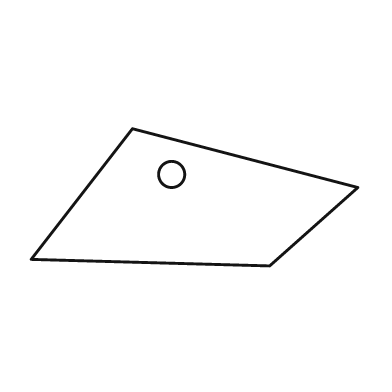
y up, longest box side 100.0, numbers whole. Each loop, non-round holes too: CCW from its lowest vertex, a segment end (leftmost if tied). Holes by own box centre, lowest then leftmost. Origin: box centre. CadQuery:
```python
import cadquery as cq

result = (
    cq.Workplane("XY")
    .moveTo(23.0, -21.0)
    .lineTo(50.0, 3.0)
    .lineTo(-19.0, 21.0)
    .lineTo(-50.0, -19.0)
    .close()
    .moveTo(-7.0, 7.0)
    .circle(4.0)
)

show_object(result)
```